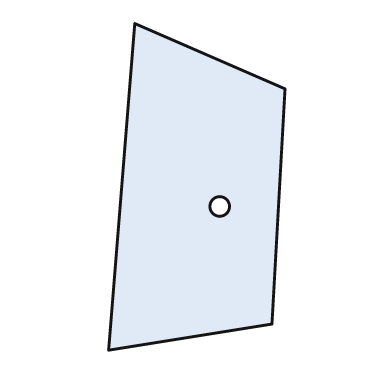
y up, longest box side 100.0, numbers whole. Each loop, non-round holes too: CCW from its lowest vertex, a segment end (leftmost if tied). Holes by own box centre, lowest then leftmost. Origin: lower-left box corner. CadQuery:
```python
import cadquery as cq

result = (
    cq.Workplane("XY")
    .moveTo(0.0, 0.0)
    .lineTo(50.0, 8.0)
    .lineTo(54.0, 80.0)
    .lineTo(8.0, 100.0)
    .close()
    .moveTo(34.0, 44.0)
    .circle(3.0)
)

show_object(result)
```